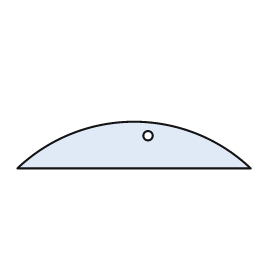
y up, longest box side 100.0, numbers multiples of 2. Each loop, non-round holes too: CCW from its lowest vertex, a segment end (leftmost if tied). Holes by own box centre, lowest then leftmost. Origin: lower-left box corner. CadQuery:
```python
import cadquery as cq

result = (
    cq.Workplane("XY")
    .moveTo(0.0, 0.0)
    .lineTo(100.0, 0.0)
    .threePointArc((50.0, 20.0), (0.0, 0.0))
    .close()
    .moveTo(56.0, 14.0)
    .circle(2.0)
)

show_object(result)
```